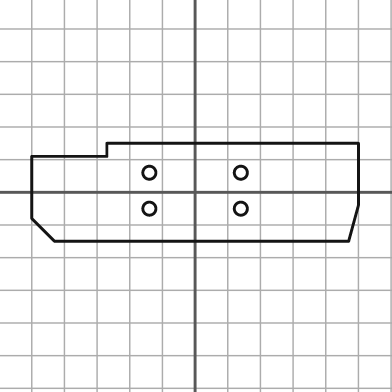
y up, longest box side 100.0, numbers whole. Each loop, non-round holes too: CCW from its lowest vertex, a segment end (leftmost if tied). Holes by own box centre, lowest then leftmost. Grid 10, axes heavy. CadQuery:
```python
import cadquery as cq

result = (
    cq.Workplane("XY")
    .moveTo(-43.0, -15.0)
    .lineTo(47.0, -15.0)
    .lineTo(50.0, -4.0)
    .lineTo(50.0, 15.0)
    .lineTo(-27.0, 15.0)
    .lineTo(-27.0, 11.0)
    .lineTo(-50.0, 11.0)
    .lineTo(-50.0, -8.0)
    .close()
    .moveTo(-14.0, -5.0)
    .circle(2.0)
    .moveTo(14.0, -5.0)
    .circle(2.0)
    .moveTo(-14.0, 6.0)
    .circle(2.0)
    .moveTo(14.0, 6.0)
    .circle(2.0)
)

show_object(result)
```